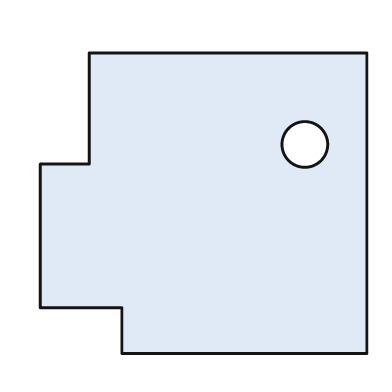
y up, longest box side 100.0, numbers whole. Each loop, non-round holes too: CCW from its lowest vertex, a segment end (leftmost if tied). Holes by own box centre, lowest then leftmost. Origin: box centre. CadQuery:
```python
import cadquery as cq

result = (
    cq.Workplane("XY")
    .moveTo(-25.0, -46.0)
    .lineTo(50.0, -46.0)
    .lineTo(50.0, 46.0)
    .lineTo(-35.0, 46.0)
    .lineTo(-35.0, 12.0)
    .lineTo(-50.0, 12.0)
    .lineTo(-50.0, -32.0)
    .lineTo(-25.0, -32.0)
    .close()
    .moveTo(31.0, 18.0)
    .circle(7.0)
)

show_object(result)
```